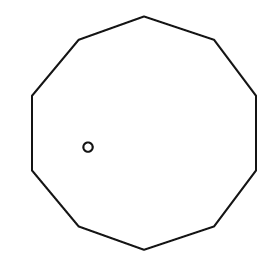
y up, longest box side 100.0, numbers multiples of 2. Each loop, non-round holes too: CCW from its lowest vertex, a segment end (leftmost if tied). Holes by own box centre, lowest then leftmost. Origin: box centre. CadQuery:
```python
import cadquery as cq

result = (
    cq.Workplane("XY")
    .moveTo(0.0, -50.0)
    .lineTo(30.0, -40.0)
    .lineTo(48.0, -16.0)
    .lineTo(48.0, 16.0)
    .lineTo(30.0, 40.0)
    .lineTo(0.0, 50.0)
    .lineTo(-28.0, 40.0)
    .lineTo(-48.0, 16.0)
    .lineTo(-48.0, -16.0)
    .lineTo(-28.0, -40.0)
    .close()
    .moveTo(-24.0, -6.0)
    .circle(2.0)
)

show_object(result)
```